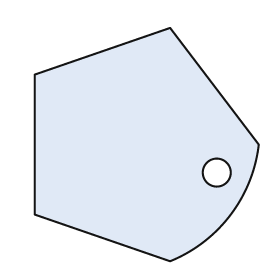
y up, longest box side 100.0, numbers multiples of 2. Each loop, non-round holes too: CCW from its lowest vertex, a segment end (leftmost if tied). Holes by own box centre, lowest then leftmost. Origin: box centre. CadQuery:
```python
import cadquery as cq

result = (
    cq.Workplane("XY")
    .moveTo(10.0, -50.0)
    .threePointArc((36.0, -30.0), (48.0, 0.0))
    .lineTo(10.0, 50.0)
    .lineTo(-48.0, 30.0)
    .lineTo(-48.0, -30.0)
    .close()
    .moveTo(30.0, -12.0)
    .circle(6.0)
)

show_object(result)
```